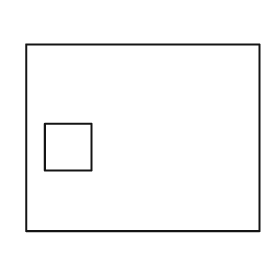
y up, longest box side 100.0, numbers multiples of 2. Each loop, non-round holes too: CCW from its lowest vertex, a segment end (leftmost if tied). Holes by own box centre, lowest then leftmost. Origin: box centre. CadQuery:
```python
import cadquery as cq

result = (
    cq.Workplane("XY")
    .moveTo(-50.0, -40.0)
    .lineTo(50.0, -40.0)
    .lineTo(50.0, 40.0)
    .lineTo(-50.0, 40.0)
    .close()
    .moveTo(-42.0, -14.0)
    .lineTo(-22.0, -14.0)
    .lineTo(-22.0, 6.0)
    .lineTo(-42.0, 6.0)
    .close()
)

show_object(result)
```